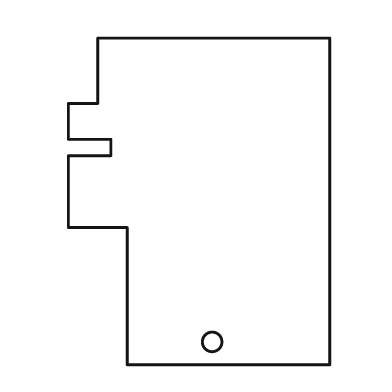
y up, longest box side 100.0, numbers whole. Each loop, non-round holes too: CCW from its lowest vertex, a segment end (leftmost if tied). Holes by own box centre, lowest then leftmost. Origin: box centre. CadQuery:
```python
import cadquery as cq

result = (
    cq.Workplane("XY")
    .moveTo(-22.0, -50.0)
    .lineTo(40.0, -50.0)
    .lineTo(40.0, 50.0)
    .lineTo(-31.0, 50.0)
    .lineTo(-31.0, 30.0)
    .lineTo(-40.0, 30.0)
    .lineTo(-40.0, 19.0)
    .lineTo(-27.0, 19.0)
    .lineTo(-27.0, 14.0)
    .lineTo(-40.0, 14.0)
    .lineTo(-40.0, -8.0)
    .lineTo(-22.0, -8.0)
    .close()
    .moveTo(4.0, -43.0)
    .circle(3.0)
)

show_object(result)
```